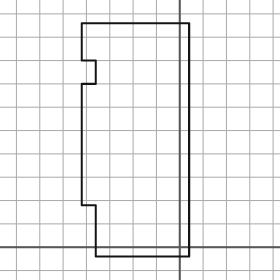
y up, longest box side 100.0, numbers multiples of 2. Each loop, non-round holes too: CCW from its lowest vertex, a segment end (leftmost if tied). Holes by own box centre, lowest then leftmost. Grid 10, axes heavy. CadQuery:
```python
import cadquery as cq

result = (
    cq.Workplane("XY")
    .moveTo(-36.0, -4.0)
    .lineTo(4.0, -4.0)
    .lineTo(4.0, 96.0)
    .lineTo(-42.0, 96.0)
    .lineTo(-42.0, 80.0)
    .lineTo(-36.0, 80.0)
    .lineTo(-36.0, 70.0)
    .lineTo(-42.0, 70.0)
    .lineTo(-42.0, 18.0)
    .lineTo(-36.0, 18.0)
    .close()
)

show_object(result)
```